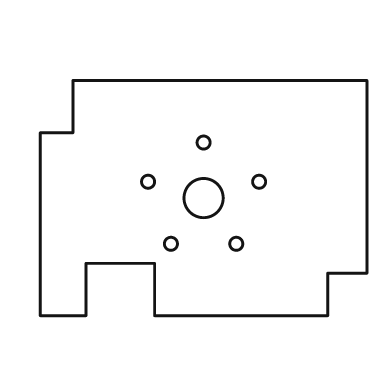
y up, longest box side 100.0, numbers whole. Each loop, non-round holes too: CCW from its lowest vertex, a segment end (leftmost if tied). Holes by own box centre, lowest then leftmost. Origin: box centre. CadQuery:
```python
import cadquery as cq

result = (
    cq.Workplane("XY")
    .moveTo(-50.0, -36.0)
    .lineTo(-36.0, -36.0)
    .lineTo(-36.0, -20.0)
    .lineTo(-15.0, -20.0)
    .lineTo(-15.0, -36.0)
    .lineTo(38.0, -36.0)
    .lineTo(38.0, -23.0)
    .lineTo(50.0, -23.0)
    .lineTo(50.0, 36.0)
    .lineTo(-40.0, 36.0)
    .lineTo(-40.0, 20.0)
    .lineTo(-50.0, 20.0)
    .close()
    .moveTo(-10.0, -14.0)
    .circle(2.0)
    .moveTo(10.0, -14.0)
    .circle(2.0)
    .moveTo(0.0, 0.0)
    .circle(6.0)
    .moveTo(-17.0, 5.0)
    .circle(2.0)
    .moveTo(17.0, 5.0)
    .circle(2.0)
    .moveTo(0.0, 17.0)
    .circle(2.0)
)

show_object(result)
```